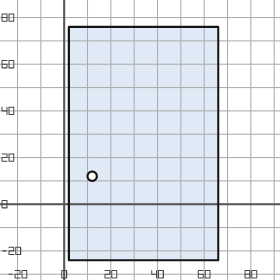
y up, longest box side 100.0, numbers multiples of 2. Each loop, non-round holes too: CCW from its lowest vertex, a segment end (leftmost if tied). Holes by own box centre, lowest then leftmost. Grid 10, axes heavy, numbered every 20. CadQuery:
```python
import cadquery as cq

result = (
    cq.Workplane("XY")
    .moveTo(2.0, -24.0)
    .lineTo(66.0, -24.0)
    .lineTo(66.0, 76.0)
    .lineTo(2.0, 76.0)
    .close()
    .moveTo(12.0, 12.0)
    .circle(2.0)
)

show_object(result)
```